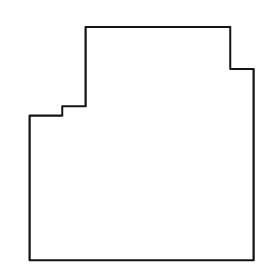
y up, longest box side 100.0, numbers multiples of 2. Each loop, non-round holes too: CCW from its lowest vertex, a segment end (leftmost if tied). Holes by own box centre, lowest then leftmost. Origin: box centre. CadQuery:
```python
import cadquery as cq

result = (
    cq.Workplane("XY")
    .moveTo(-48.0, -50.0)
    .lineTo(48.0, -50.0)
    .lineTo(48.0, 32.0)
    .lineTo(38.0, 32.0)
    .lineTo(38.0, 50.0)
    .lineTo(-24.0, 50.0)
    .lineTo(-24.0, 16.0)
    .lineTo(-34.0, 16.0)
    .lineTo(-34.0, 12.0)
    .lineTo(-48.0, 12.0)
    .close()
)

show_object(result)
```